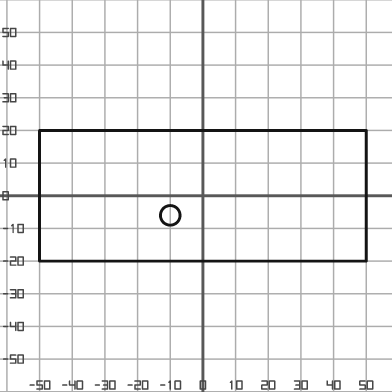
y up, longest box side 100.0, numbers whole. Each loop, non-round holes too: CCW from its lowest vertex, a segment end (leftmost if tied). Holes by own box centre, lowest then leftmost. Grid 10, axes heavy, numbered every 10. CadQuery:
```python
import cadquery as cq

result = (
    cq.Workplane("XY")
    .moveTo(-50.0, -20.0)
    .lineTo(50.0, -20.0)
    .lineTo(50.0, 20.0)
    .lineTo(-50.0, 20.0)
    .close()
    .moveTo(-10.0, -6.0)
    .circle(3.0)
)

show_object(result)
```